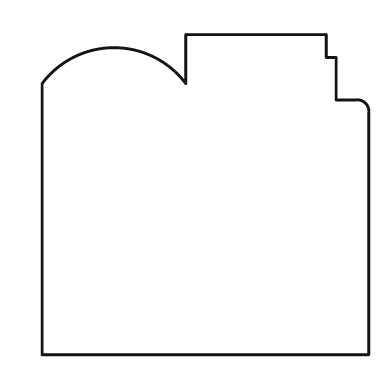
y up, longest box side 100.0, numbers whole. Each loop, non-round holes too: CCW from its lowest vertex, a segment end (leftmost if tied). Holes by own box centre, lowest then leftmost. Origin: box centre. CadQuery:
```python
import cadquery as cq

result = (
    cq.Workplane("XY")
    .moveTo(-50.0, -49.0)
    .lineTo(50.0, -49.0)
    .lineTo(50.0, 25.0)
    .threePointArc((49.0, 28.0), (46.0, 29.0))
    .lineTo(40.0, 29.0)
    .lineTo(40.0, 42.0)
    .lineTo(37.0, 42.0)
    .lineTo(37.0, 49.0)
    .lineTo(-6.0, 49.0)
    .lineTo(-6.0, 34.0)
    .threePointArc((-28.0, 45.0), (-50.0, 34.0))
    .close()
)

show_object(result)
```